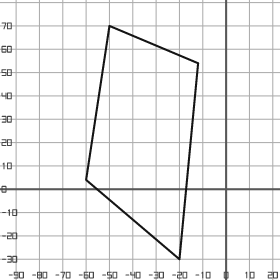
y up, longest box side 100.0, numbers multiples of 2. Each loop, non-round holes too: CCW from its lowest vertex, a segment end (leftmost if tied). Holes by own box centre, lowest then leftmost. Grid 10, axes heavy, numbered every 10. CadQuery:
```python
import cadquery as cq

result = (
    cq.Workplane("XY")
    .moveTo(-20.0, -30.0)
    .lineTo(-12.0, 54.0)
    .lineTo(-50.0, 70.0)
    .lineTo(-60.0, 4.0)
    .close()
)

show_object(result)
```